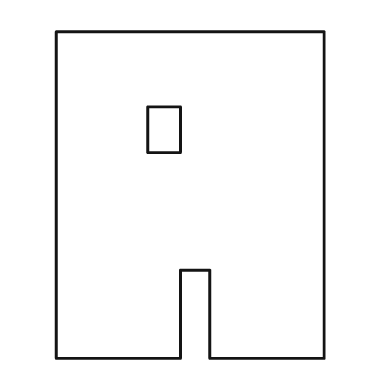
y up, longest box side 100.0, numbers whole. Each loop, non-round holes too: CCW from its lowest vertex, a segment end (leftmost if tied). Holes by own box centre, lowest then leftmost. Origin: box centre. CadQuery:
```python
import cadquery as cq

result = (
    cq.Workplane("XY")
    .moveTo(-41.0, -50.0)
    .lineTo(-3.0, -50.0)
    .lineTo(-3.0, -23.0)
    .lineTo(6.0, -23.0)
    .lineTo(6.0, -50.0)
    .lineTo(41.0, -50.0)
    .lineTo(41.0, 50.0)
    .lineTo(-41.0, 50.0)
    .close()
    .moveTo(-13.0, 13.0)
    .lineTo(-3.0, 13.0)
    .lineTo(-3.0, 27.0)
    .lineTo(-13.0, 27.0)
    .close()
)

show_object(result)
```